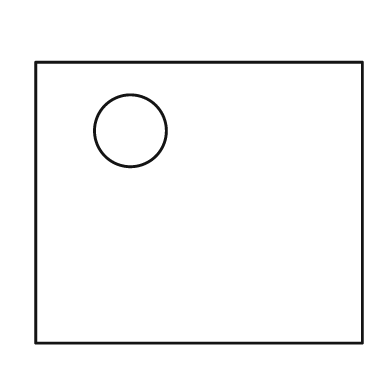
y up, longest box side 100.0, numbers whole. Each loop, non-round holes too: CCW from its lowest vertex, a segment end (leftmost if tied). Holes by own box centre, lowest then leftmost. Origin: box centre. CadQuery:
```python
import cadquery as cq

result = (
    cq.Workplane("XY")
    .moveTo(-50.0, -43.0)
    .lineTo(50.0, -43.0)
    .lineTo(50.0, 43.0)
    .lineTo(-50.0, 43.0)
    .close()
    .moveTo(-21.0, 22.0)
    .circle(11.0)
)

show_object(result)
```